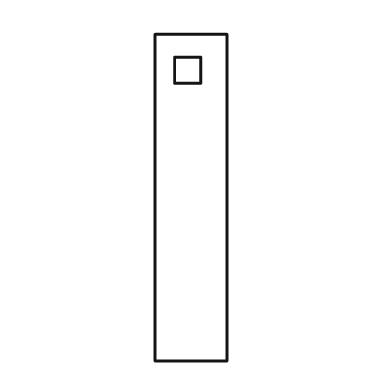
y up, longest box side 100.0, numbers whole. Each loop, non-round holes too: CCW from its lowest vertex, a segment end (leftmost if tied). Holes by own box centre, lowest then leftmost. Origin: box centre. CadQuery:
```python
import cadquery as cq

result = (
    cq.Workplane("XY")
    .moveTo(-11.0, -50.0)
    .lineTo(11.0, -50.0)
    .lineTo(11.0, 50.0)
    .lineTo(-11.0, 50.0)
    .close()
    .moveTo(-5.0, 35.0)
    .lineTo(3.0, 35.0)
    .lineTo(3.0, 43.0)
    .lineTo(-5.0, 43.0)
    .close()
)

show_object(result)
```